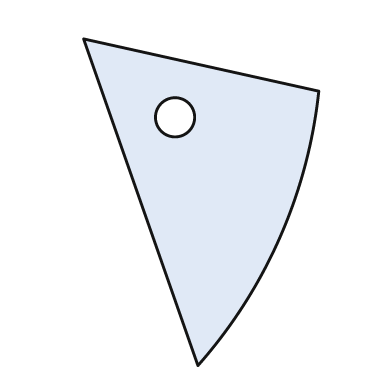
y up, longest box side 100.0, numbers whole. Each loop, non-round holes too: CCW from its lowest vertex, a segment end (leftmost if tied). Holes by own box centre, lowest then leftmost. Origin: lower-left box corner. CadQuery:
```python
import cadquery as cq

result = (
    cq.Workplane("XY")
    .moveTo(35.0, 0.0)
    .threePointArc((60.0, 39.0), (72.0, 84.0))
    .lineTo(0.0, 100.0)
    .close()
    .moveTo(28.0, 76.0)
    .circle(6.0)
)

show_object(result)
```